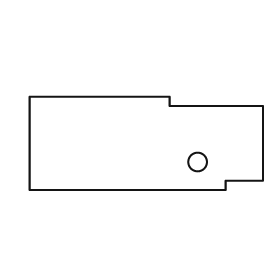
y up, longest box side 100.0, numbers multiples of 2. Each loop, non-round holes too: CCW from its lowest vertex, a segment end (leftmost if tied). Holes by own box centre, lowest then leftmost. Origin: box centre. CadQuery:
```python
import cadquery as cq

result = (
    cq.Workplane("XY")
    .moveTo(-50.0, -20.0)
    .lineTo(34.0, -20.0)
    .lineTo(34.0, -16.0)
    .lineTo(50.0, -16.0)
    .lineTo(50.0, 16.0)
    .lineTo(10.0, 16.0)
    .lineTo(10.0, 20.0)
    .lineTo(-50.0, 20.0)
    .close()
    .moveTo(22.0, -8.0)
    .circle(4.0)
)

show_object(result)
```